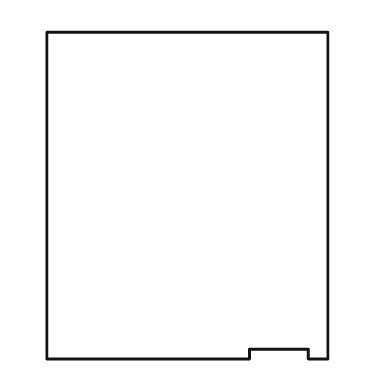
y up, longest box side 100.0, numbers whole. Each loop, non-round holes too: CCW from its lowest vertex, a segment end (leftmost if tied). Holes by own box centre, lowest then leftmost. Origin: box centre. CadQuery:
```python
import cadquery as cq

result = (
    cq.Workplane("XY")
    .moveTo(-43.0, -50.0)
    .lineTo(19.0, -50.0)
    .lineTo(19.0, -47.0)
    .lineTo(37.0, -47.0)
    .lineTo(37.0, -50.0)
    .lineTo(43.0, -50.0)
    .lineTo(43.0, 50.0)
    .lineTo(-43.0, 50.0)
    .close()
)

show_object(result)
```